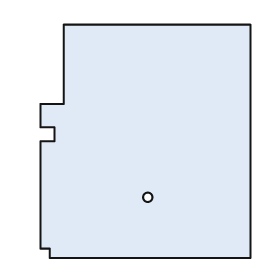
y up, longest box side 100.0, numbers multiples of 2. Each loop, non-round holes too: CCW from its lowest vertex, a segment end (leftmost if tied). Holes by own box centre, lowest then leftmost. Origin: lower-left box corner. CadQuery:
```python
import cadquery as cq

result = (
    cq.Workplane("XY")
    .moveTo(4.0, 0.0)
    .lineTo(90.0, 0.0)
    .lineTo(90.0, 100.0)
    .lineTo(10.0, 100.0)
    .lineTo(10.0, 66.0)
    .lineTo(0.0, 66.0)
    .lineTo(0.0, 56.0)
    .lineTo(6.0, 56.0)
    .lineTo(6.0, 50.0)
    .lineTo(0.0, 50.0)
    .lineTo(0.0, 4.0)
    .lineTo(4.0, 4.0)
    .close()
    .moveTo(46.0, 26.0)
    .circle(2.0)
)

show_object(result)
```